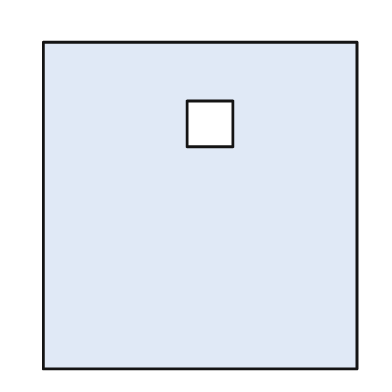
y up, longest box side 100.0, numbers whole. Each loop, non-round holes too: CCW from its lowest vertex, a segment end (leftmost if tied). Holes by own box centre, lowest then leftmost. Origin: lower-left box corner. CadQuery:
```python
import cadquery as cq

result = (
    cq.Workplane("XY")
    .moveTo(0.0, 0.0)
    .lineTo(96.0, 0.0)
    .lineTo(96.0, 100.0)
    .lineTo(0.0, 100.0)
    .close()
    .moveTo(44.0, 68.0)
    .lineTo(58.0, 68.0)
    .lineTo(58.0, 82.0)
    .lineTo(44.0, 82.0)
    .close()
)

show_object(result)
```